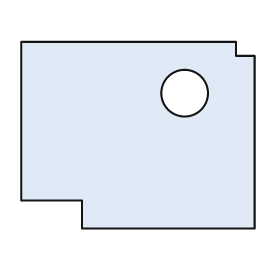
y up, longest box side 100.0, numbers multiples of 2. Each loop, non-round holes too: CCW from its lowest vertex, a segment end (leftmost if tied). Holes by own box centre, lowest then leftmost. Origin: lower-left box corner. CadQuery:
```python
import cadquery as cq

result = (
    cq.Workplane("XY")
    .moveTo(26.0, 0.0)
    .lineTo(100.0, 0.0)
    .lineTo(100.0, 74.0)
    .lineTo(92.0, 74.0)
    .lineTo(92.0, 80.0)
    .lineTo(0.0, 80.0)
    .lineTo(0.0, 12.0)
    .lineTo(26.0, 12.0)
    .close()
    .moveTo(70.0, 58.0)
    .circle(10.0)
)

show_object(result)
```